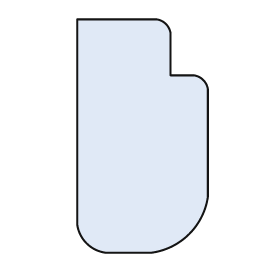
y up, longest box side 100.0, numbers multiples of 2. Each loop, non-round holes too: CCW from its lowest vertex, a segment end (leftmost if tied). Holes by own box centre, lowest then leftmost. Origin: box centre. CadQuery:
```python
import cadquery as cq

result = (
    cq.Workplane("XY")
    .moveTo(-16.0, -50.0)
    .lineTo(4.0, -50.0)
    .threePointArc((20.0, -42.0), (28.0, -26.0))
    .lineTo(28.0, 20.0)
    .threePointArc((26.0, 24.0), (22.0, 26.0))
    .lineTo(12.0, 26.0)
    .lineTo(12.0, 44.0)
    .threePointArc((10.0, 48.0), (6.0, 50.0))
    .lineTo(-28.0, 50.0)
    .lineTo(-28.0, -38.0)
    .threePointArc((-24.0, -46.0), (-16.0, -50.0))
    .close()
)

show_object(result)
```